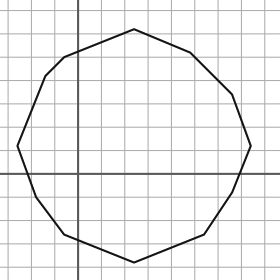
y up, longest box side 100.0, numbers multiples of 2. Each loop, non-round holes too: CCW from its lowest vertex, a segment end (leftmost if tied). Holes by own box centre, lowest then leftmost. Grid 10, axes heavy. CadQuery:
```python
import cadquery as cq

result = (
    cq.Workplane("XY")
    .moveTo(24.0, -38.0)
    .lineTo(54.0, -26.0)
    .lineTo(66.0, -8.0)
    .lineTo(74.0, 12.0)
    .lineTo(66.0, 34.0)
    .lineTo(48.0, 52.0)
    .lineTo(24.0, 62.0)
    .lineTo(-6.0, 50.0)
    .lineTo(-14.0, 42.0)
    .lineTo(-26.0, 12.0)
    .lineTo(-18.0, -10.0)
    .lineTo(-6.0, -26.0)
    .close()
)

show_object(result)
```